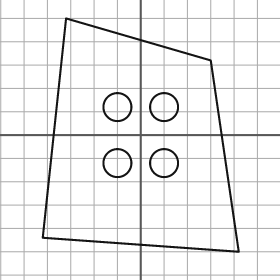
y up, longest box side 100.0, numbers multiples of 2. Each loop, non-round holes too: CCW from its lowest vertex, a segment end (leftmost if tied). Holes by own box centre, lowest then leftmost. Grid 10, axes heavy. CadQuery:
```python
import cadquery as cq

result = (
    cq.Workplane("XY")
    .moveTo(42.0, -50.0)
    .lineTo(30.0, 32.0)
    .lineTo(-32.0, 50.0)
    .lineTo(-42.0, -44.0)
    .close()
    .moveTo(-10.0, -12.0)
    .circle(6.0)
    .moveTo(10.0, -12.0)
    .circle(6.0)
    .moveTo(-10.0, 12.0)
    .circle(6.0)
    .moveTo(10.0, 12.0)
    .circle(6.0)
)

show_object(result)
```